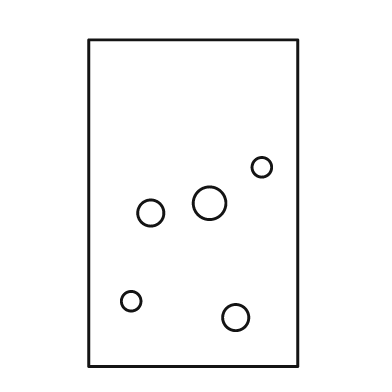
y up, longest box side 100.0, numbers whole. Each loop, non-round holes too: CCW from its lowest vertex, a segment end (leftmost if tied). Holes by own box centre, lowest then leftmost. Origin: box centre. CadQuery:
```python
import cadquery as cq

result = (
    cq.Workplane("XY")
    .moveTo(-32.0, -50.0)
    .lineTo(32.0, -50.0)
    .lineTo(32.0, 50.0)
    .lineTo(-32.0, 50.0)
    .close()
    .moveTo(13.0, -35.0)
    .circle(4.0)
    .moveTo(-19.0, -30.0)
    .circle(3.0)
    .moveTo(-13.0, -3.0)
    .circle(4.0)
    .moveTo(5.0, 0.0)
    .circle(5.0)
    .moveTo(21.0, 11.0)
    .circle(3.0)
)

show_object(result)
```